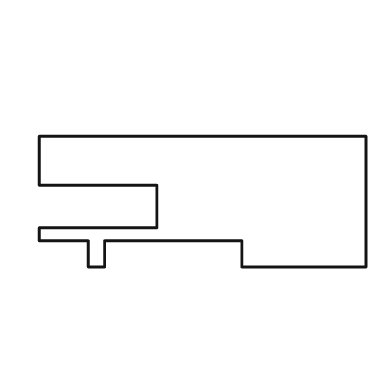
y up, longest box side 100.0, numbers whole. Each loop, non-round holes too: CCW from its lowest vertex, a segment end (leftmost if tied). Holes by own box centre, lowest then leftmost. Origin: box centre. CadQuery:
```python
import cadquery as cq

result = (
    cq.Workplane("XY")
    .moveTo(-35.0, -20.0)
    .lineTo(-30.0, -20.0)
    .lineTo(-30.0, -12.0)
    .lineTo(12.0, -12.0)
    .lineTo(12.0, -20.0)
    .lineTo(50.0, -20.0)
    .lineTo(50.0, 20.0)
    .lineTo(-50.0, 20.0)
    .lineTo(-50.0, 5.0)
    .lineTo(-14.0, 5.0)
    .lineTo(-14.0, -8.0)
    .lineTo(-50.0, -8.0)
    .lineTo(-50.0, -12.0)
    .lineTo(-35.0, -12.0)
    .close()
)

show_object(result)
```